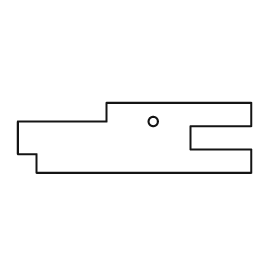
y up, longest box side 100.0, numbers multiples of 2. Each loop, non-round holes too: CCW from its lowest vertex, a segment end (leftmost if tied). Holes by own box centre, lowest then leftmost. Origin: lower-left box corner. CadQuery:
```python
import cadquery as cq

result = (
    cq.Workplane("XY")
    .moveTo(8.0, 0.0)
    .lineTo(100.0, 0.0)
    .lineTo(100.0, 10.0)
    .lineTo(74.0, 10.0)
    .lineTo(74.0, 20.0)
    .lineTo(100.0, 20.0)
    .lineTo(100.0, 30.0)
    .lineTo(38.0, 30.0)
    .lineTo(38.0, 22.0)
    .lineTo(0.0, 22.0)
    .lineTo(0.0, 8.0)
    .lineTo(8.0, 8.0)
    .close()
    .moveTo(58.0, 22.0)
    .circle(2.0)
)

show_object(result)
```